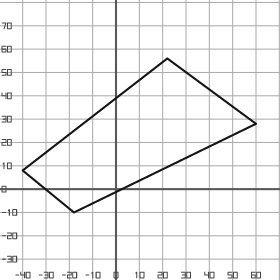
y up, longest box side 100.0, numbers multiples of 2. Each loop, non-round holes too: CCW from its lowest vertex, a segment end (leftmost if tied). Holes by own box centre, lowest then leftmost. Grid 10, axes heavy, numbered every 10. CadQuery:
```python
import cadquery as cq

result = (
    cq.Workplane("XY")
    .moveTo(-18.0, -10.0)
    .lineTo(60.0, 28.0)
    .lineTo(22.0, 56.0)
    .lineTo(-40.0, 8.0)
    .close()
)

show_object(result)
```